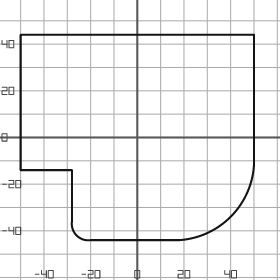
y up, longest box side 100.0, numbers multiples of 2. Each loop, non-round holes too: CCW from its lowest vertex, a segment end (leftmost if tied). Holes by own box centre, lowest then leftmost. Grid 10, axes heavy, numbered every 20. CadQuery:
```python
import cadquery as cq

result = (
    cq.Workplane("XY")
    .moveTo(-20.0, -44.0)
    .lineTo(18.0, -44.0)
    .threePointArc((40.0, -34.0), (50.0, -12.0))
    .lineTo(50.0, 44.0)
    .lineTo(-50.0, 44.0)
    .lineTo(-50.0, -14.0)
    .lineTo(-28.0, -14.0)
    .lineTo(-28.0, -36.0)
    .threePointArc((-26.0, -42.0), (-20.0, -44.0))
    .close()
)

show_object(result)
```